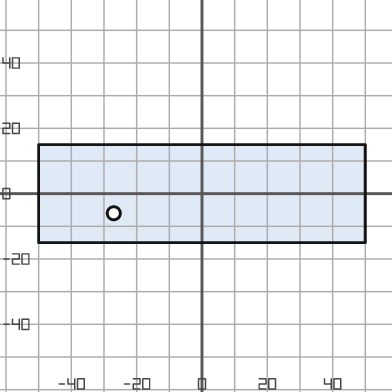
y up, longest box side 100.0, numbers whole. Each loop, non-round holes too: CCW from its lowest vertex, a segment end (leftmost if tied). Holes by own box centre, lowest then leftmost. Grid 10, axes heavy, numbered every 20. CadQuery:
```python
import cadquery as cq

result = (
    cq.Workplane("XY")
    .moveTo(-50.0, -15.0)
    .lineTo(50.0, -15.0)
    .lineTo(50.0, 15.0)
    .lineTo(-50.0, 15.0)
    .close()
    .moveTo(-27.0, -6.0)
    .circle(2.0)
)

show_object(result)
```